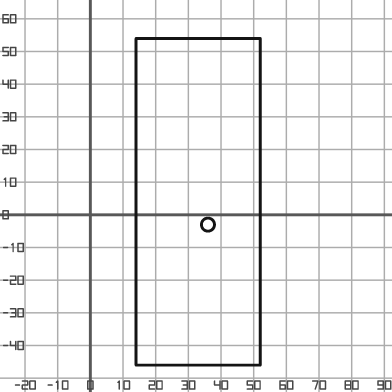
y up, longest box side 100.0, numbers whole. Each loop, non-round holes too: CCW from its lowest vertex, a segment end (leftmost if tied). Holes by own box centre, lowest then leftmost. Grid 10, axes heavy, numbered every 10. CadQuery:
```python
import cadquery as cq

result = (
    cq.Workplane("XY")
    .moveTo(14.0, -46.0)
    .lineTo(52.0, -46.0)
    .lineTo(52.0, 54.0)
    .lineTo(14.0, 54.0)
    .close()
    .moveTo(36.0, -3.0)
    .circle(2.0)
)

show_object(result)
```